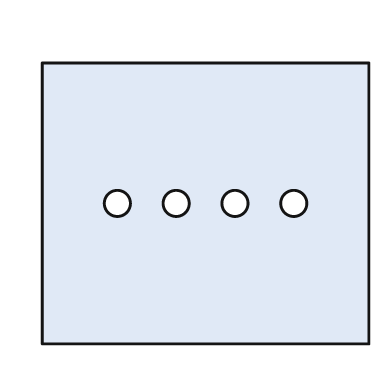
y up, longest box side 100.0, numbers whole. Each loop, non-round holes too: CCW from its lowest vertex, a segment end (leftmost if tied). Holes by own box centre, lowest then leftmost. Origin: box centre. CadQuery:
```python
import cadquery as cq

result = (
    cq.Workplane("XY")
    .moveTo(-50.0, -43.0)
    .lineTo(50.0, -43.0)
    .lineTo(50.0, 43.0)
    .lineTo(-50.0, 43.0)
    .close()
    .moveTo(-27.0, 0.0)
    .circle(4.0)
    .moveTo(-9.0, 0.0)
    .circle(4.0)
    .moveTo(9.0, 0.0)
    .circle(4.0)
    .moveTo(27.0, 0.0)
    .circle(4.0)
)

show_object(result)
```